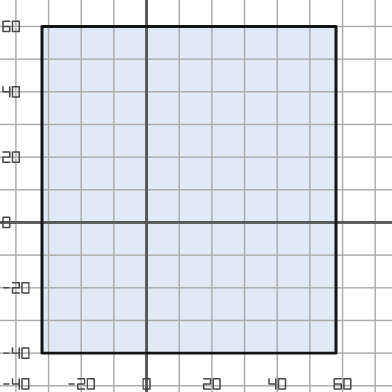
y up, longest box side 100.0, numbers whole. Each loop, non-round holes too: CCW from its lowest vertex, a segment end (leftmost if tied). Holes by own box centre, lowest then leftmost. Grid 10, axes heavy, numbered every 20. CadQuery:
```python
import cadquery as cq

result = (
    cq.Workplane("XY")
    .moveTo(-32.0, -40.0)
    .lineTo(58.0, -40.0)
    .lineTo(58.0, 60.0)
    .lineTo(-32.0, 60.0)
    .close()
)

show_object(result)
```